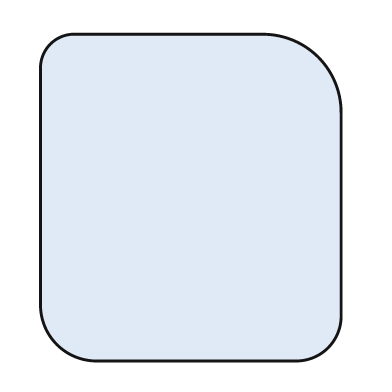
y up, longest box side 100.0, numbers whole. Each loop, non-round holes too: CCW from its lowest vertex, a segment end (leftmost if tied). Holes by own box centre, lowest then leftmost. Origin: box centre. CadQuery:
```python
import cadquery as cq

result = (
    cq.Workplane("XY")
    .moveTo(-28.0, -50.0)
    .lineTo(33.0, -50.0)
    .threePointArc((42.0, -46.0), (46.0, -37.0))
    .lineTo(46.0, 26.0)
    .threePointArc((39.0, 43.0), (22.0, 50.0))
    .lineTo(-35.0, 50.0)
    .threePointArc((-43.0, 47.0), (-46.0, 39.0))
    .lineTo(-46.0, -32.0)
    .threePointArc((-41.0, -45.0), (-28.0, -50.0))
    .close()
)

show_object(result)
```